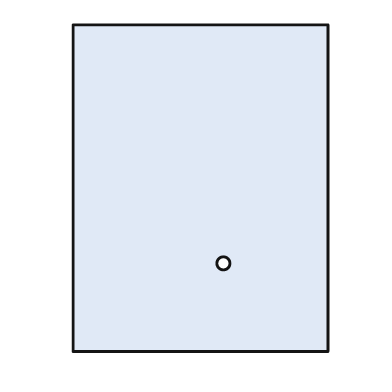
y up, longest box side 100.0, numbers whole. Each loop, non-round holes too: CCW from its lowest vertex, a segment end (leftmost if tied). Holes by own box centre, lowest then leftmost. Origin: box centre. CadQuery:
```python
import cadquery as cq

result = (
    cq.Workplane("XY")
    .moveTo(-39.0, -50.0)
    .lineTo(39.0, -50.0)
    .lineTo(39.0, 50.0)
    .lineTo(-39.0, 50.0)
    .close()
    .moveTo(7.0, -23.0)
    .circle(2.0)
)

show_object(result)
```